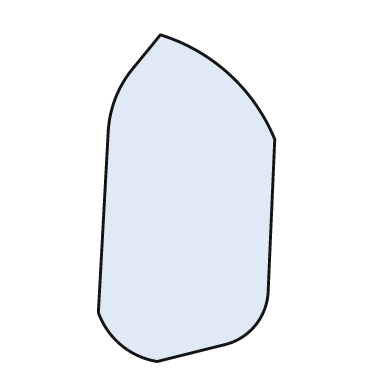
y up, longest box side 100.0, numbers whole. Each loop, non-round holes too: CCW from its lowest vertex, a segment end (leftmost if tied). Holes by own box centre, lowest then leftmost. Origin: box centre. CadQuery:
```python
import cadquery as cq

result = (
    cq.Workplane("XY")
    .moveTo(-9.0, -50.0)
    .lineTo(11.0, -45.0)
    .threePointArc((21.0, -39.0), (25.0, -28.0))
    .lineTo(27.0, 18.0)
    .threePointArc((13.0, 38.0), (-8.0, 50.0))
    .lineTo(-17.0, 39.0)
    .threePointArc((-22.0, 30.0), (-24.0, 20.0))
    .lineTo(-27.0, -35.0)
    .threePointArc((-20.0, -45.0), (-9.0, -50.0))
    .close()
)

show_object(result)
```